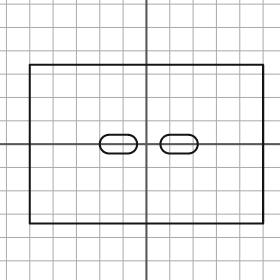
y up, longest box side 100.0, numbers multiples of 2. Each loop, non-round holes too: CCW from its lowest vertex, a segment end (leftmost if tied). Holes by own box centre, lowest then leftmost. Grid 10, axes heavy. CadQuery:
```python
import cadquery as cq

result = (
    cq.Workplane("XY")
    .moveTo(-50.0, -34.0)
    .lineTo(50.0, -34.0)
    .lineTo(50.0, 34.0)
    .lineTo(-50.0, 34.0)
    .close()
    .moveTo(-16.0, -4.0)
    .lineTo(-8.0, -4.0)
    .threePointArc((-4.0, 0.0), (-8.0, 4.0))
    .lineTo(-16.0, 4.0)
    .threePointArc((-20.0, 0.0), (-16.0, -4.0))
    .close()
    .moveTo(10.0, -4.0)
    .lineTo(18.0, -4.0)
    .threePointArc((22.0, 0.0), (18.0, 4.0))
    .lineTo(10.0, 4.0)
    .threePointArc((6.0, 0.0), (10.0, -4.0))
    .close()
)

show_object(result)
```